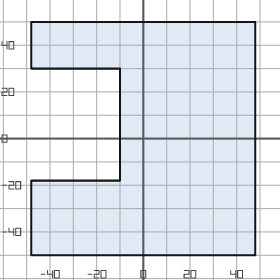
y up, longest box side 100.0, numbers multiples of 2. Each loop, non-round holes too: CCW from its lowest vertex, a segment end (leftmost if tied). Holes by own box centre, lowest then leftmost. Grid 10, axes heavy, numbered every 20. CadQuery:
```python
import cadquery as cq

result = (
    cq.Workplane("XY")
    .moveTo(-48.0, -50.0)
    .lineTo(48.0, -50.0)
    .lineTo(48.0, 50.0)
    .lineTo(-48.0, 50.0)
    .lineTo(-48.0, 30.0)
    .lineTo(-10.0, 30.0)
    .lineTo(-10.0, -18.0)
    .lineTo(-48.0, -18.0)
    .close()
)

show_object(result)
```